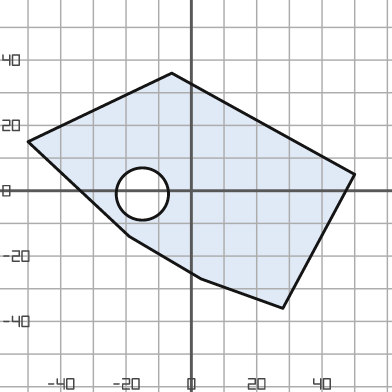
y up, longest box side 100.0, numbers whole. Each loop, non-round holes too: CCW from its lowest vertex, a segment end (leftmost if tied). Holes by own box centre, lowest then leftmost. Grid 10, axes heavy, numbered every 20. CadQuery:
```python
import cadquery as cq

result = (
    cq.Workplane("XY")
    .moveTo(28.0, -36.0)
    .lineTo(50.0, 5.0)
    .lineTo(-6.0, 36.0)
    .lineTo(-50.0, 15.0)
    .lineTo(-19.0, -14.0)
    .lineTo(3.0, -27.0)
    .close()
    .moveTo(-15.0, -1.0)
    .circle(8.0)
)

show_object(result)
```